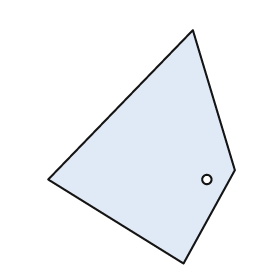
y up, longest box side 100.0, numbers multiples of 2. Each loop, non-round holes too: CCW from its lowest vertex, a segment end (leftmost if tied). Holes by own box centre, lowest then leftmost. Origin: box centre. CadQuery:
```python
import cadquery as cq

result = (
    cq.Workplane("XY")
    .moveTo(18.0, -50.0)
    .lineTo(40.0, -10.0)
    .lineTo(22.0, 50.0)
    .lineTo(-40.0, -14.0)
    .close()
    .moveTo(28.0, -14.0)
    .circle(2.0)
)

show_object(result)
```